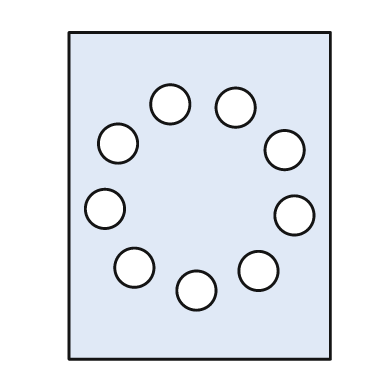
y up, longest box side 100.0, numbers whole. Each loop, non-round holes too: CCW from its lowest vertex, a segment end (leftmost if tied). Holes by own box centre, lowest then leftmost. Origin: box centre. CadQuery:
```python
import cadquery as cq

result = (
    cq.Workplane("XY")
    .moveTo(-40.0, -50.0)
    .lineTo(40.0, -50.0)
    .lineTo(40.0, 50.0)
    .lineTo(-40.0, 50.0)
    .close()
    .moveTo(-1.0, -29.0)
    .circle(6.0)
    .moveTo(18.0, -23.0)
    .circle(6.0)
    .moveTo(-20.0, -22.0)
    .circle(6.0)
    .moveTo(29.0, -6.0)
    .circle(6.0)
    .moveTo(-29.0, -4.0)
    .circle(6.0)
    .moveTo(26.0, 14.0)
    .circle(6.0)
    .moveTo(-25.0, 16.0)
    .circle(6.0)
    .moveTo(11.0, 27.0)
    .circle(6.0)
    .moveTo(-9.0, 28.0)
    .circle(6.0)
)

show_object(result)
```